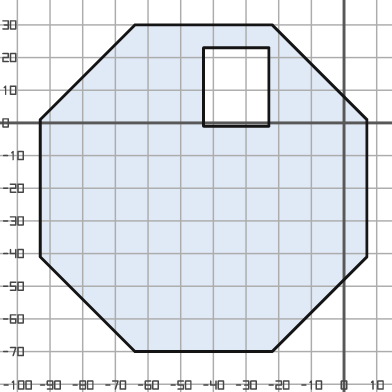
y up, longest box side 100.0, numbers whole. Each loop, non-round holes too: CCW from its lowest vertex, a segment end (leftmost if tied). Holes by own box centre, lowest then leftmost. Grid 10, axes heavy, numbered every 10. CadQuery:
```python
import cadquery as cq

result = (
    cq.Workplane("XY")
    .moveTo(-64.0, -70.0)
    .lineTo(-22.0, -70.0)
    .lineTo(7.0, -41.0)
    .lineTo(7.0, 1.0)
    .lineTo(-22.0, 30.0)
    .lineTo(-64.0, 30.0)
    .lineTo(-93.0, 1.0)
    .lineTo(-93.0, -41.0)
    .close()
    .moveTo(-43.0, -1.0)
    .lineTo(-23.0, -1.0)
    .lineTo(-23.0, 23.0)
    .lineTo(-43.0, 23.0)
    .close()
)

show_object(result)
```